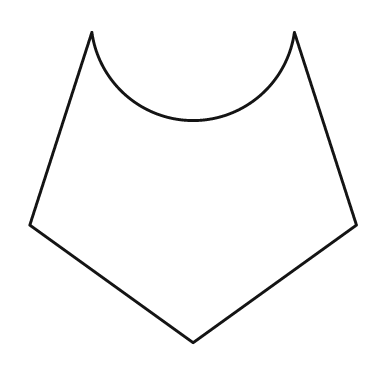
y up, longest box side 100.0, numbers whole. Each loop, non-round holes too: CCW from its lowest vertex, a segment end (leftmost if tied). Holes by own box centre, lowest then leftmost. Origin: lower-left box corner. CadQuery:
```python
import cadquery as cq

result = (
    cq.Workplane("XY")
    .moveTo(50.0, 0.0)
    .lineTo(100.0, 36.0)
    .lineTo(81.0, 95.0)
    .threePointArc((50.0, 68.0), (19.0, 95.0))
    .lineTo(0.0, 36.0)
    .close()
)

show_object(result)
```